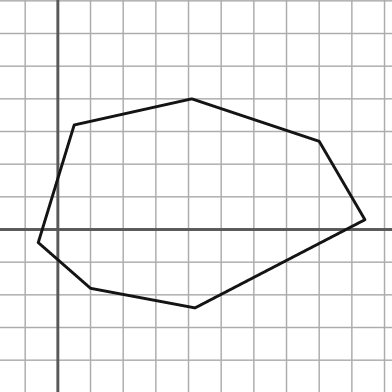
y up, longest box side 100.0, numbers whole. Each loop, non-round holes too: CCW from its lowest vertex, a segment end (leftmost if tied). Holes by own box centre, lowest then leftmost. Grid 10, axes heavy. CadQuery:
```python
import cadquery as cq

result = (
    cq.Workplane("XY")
    .moveTo(42.0, -24.0)
    .lineTo(94.0, 3.0)
    .lineTo(80.0, 27.0)
    .lineTo(41.0, 40.0)
    .lineTo(5.0, 32.0)
    .lineTo(-6.0, -4.0)
    .lineTo(10.0, -18.0)
    .close()
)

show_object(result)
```